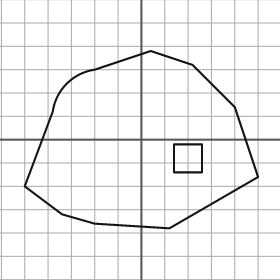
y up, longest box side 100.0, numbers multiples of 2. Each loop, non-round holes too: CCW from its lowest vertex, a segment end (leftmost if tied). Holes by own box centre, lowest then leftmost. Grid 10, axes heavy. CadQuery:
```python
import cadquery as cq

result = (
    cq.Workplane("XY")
    .moveTo(12.0, -38.0)
    .lineTo(50.0, -16.0)
    .lineTo(40.0, 14.0)
    .lineTo(22.0, 32.0)
    .lineTo(4.0, 38.0)
    .lineTo(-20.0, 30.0)
    .threePointArc((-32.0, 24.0), (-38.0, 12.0))
    .lineTo(-50.0, -20.0)
    .lineTo(-34.0, -32.0)
    .lineTo(-20.0, -36.0)
    .close()
    .moveTo(14.0, -14.0)
    .lineTo(26.0, -14.0)
    .lineTo(26.0, -2.0)
    .lineTo(14.0, -2.0)
    .close()
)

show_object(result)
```